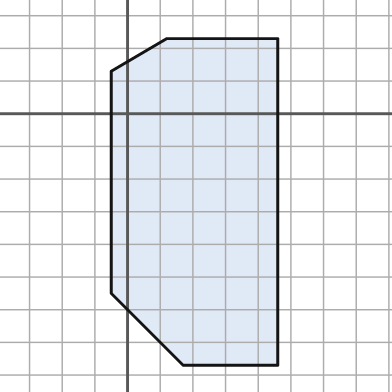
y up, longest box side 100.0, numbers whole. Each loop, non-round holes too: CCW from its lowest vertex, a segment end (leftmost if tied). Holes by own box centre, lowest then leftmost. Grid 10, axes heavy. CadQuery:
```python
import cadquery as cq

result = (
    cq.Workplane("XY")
    .moveTo(17.0, -77.0)
    .lineTo(46.0, -77.0)
    .lineTo(46.0, 23.0)
    .lineTo(12.0, 23.0)
    .lineTo(-5.0, 13.0)
    .lineTo(-5.0, -55.0)
    .close()
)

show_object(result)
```